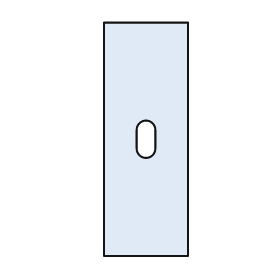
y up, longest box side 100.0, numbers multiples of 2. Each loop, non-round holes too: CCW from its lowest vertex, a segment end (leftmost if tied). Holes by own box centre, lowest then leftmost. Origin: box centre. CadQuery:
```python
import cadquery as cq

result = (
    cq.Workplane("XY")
    .moveTo(-18.0, -50.0)
    .lineTo(18.0, -50.0)
    .lineTo(18.0, 50.0)
    .lineTo(-18.0, 50.0)
    .close()
    .moveTo(-4.0, -4.0)
    .threePointArc((0.0, -8.0), (4.0, -4.0))
    .lineTo(4.0, 4.0)
    .threePointArc((0.0, 8.0), (-4.0, 4.0))
    .close()
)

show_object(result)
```